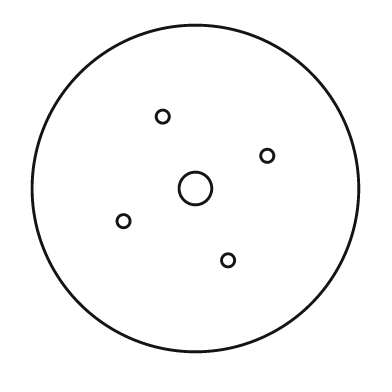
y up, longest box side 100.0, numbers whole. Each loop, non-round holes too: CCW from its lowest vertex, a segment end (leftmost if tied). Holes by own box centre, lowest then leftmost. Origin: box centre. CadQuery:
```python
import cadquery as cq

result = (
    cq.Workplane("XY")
    .moveTo(0.0, 0.0)
    .circle(50.0)
    .moveTo(10.0, -22.0)
    .circle(2.0)
    .moveTo(-22.0, -10.0)
    .circle(2.0)
    .moveTo(0.0, 0.0)
    .circle(5.0)
    .moveTo(22.0, 10.0)
    .circle(2.0)
    .moveTo(-10.0, 22.0)
    .circle(2.0)
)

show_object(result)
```